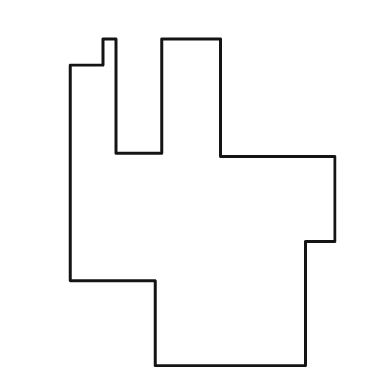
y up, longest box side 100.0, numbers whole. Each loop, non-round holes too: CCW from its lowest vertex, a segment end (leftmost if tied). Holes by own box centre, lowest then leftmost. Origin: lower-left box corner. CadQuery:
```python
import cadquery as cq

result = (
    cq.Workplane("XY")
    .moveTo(26.0, 0.0)
    .lineTo(72.0, 0.0)
    .lineTo(72.0, 38.0)
    .lineTo(81.0, 38.0)
    .lineTo(81.0, 64.0)
    .lineTo(46.0, 64.0)
    .lineTo(46.0, 100.0)
    .lineTo(28.0, 100.0)
    .lineTo(28.0, 65.0)
    .lineTo(14.0, 65.0)
    .lineTo(14.0, 100.0)
    .lineTo(10.0, 100.0)
    .lineTo(10.0, 92.0)
    .lineTo(0.0, 92.0)
    .lineTo(0.0, 26.0)
    .lineTo(26.0, 26.0)
    .close()
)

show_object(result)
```